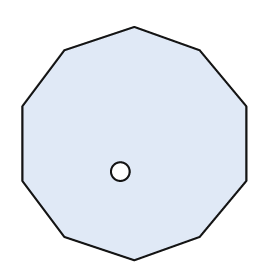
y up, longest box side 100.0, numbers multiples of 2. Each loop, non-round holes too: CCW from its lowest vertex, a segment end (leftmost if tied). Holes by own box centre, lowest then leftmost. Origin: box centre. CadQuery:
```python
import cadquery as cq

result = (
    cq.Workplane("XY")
    .moveTo(0.0, -50.0)
    .lineTo(28.0, -40.0)
    .lineTo(48.0, -16.0)
    .lineTo(48.0, 16.0)
    .lineTo(28.0, 40.0)
    .lineTo(0.0, 50.0)
    .lineTo(-30.0, 40.0)
    .lineTo(-48.0, 16.0)
    .lineTo(-48.0, -16.0)
    .lineTo(-30.0, -40.0)
    .close()
    .moveTo(-6.0, -12.0)
    .circle(4.0)
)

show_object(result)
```